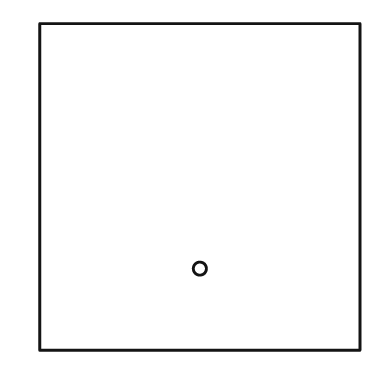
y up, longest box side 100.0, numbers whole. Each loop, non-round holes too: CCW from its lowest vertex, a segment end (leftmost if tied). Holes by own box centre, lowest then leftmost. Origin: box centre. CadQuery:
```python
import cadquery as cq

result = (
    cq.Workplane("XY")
    .moveTo(-49.0, -50.0)
    .lineTo(49.0, -50.0)
    .lineTo(49.0, 50.0)
    .lineTo(-49.0, 50.0)
    .close()
    .moveTo(0.0, -25.0)
    .circle(2.0)
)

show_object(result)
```